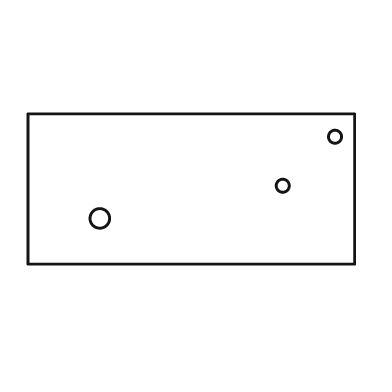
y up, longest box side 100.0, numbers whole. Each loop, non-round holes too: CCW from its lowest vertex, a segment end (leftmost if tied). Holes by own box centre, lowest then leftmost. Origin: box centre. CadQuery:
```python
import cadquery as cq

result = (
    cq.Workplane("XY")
    .moveTo(-50.0, -23.0)
    .lineTo(50.0, -23.0)
    .lineTo(50.0, 23.0)
    .lineTo(-50.0, 23.0)
    .close()
    .moveTo(-28.0, -9.0)
    .circle(3.0)
    .moveTo(28.0, 1.0)
    .circle(2.0)
    .moveTo(44.0, 16.0)
    .circle(2.0)
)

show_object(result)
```